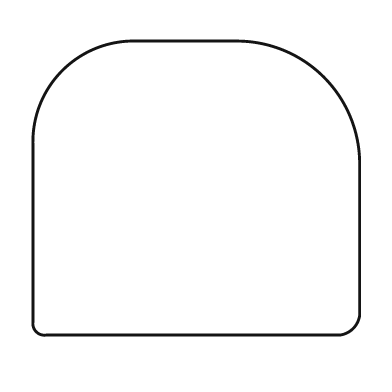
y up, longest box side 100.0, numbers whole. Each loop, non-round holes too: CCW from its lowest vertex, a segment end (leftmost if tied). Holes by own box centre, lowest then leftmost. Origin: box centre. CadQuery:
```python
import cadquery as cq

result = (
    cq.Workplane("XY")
    .moveTo(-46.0, -45.0)
    .lineTo(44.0, -45.0)
    .threePointArc((48.0, -43.0), (50.0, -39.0))
    .lineTo(50.0, 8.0)
    .threePointArc((39.0, 34.0), (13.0, 45.0))
    .lineTo(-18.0, 45.0)
    .threePointArc((-41.0, 36.0), (-50.0, 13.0))
    .lineTo(-50.0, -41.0)
    .threePointArc((-49.0, -44.0), (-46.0, -45.0))
    .close()
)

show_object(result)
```